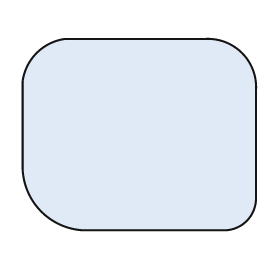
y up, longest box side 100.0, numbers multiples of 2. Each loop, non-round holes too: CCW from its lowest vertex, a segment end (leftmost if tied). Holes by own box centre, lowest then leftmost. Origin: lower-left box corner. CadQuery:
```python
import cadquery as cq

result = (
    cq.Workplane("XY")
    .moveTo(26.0, 0.0)
    .lineTo(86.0, 0.0)
    .threePointArc((96.0, 4.0), (100.0, 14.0))
    .lineTo(100.0, 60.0)
    .threePointArc((94.0, 76.0), (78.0, 82.0))
    .lineTo(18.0, 82.0)
    .threePointArc((6.0, 76.0), (0.0, 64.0))
    .lineTo(0.0, 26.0)
    .threePointArc((8.0, 8.0), (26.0, 0.0))
    .close()
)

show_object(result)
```